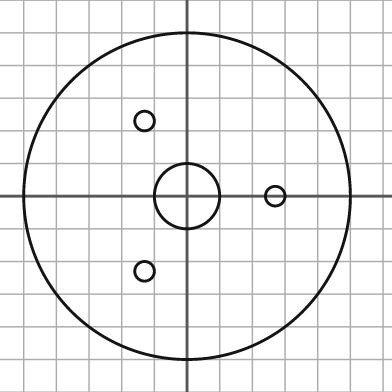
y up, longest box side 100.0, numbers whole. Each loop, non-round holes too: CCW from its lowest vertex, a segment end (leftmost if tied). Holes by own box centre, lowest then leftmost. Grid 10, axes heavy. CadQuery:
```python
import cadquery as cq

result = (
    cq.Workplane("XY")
    .moveTo(0.0, 0.0)
    .circle(50.0)
    .moveTo(-13.0, -23.0)
    .circle(3.0)
    .moveTo(0.0, 0.0)
    .circle(10.0)
    .moveTo(27.0, 0.0)
    .circle(3.0)
    .moveTo(-13.0, 23.0)
    .circle(3.0)
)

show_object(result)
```